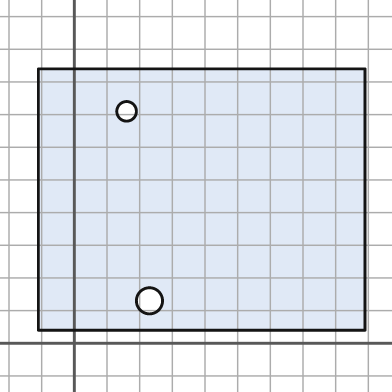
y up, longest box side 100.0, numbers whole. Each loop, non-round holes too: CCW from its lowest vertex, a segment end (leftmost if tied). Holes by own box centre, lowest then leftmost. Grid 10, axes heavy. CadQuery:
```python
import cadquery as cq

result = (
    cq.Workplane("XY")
    .moveTo(-11.0, 4.0)
    .lineTo(89.0, 4.0)
    .lineTo(89.0, 84.0)
    .lineTo(-11.0, 84.0)
    .close()
    .moveTo(23.0, 13.0)
    .circle(4.0)
    .moveTo(16.0, 71.0)
    .circle(3.0)
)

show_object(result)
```